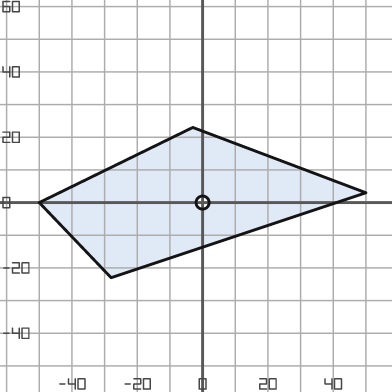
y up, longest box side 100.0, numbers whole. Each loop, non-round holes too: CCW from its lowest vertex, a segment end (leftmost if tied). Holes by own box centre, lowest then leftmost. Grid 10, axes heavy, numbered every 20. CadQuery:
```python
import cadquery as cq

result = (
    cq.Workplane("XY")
    .moveTo(-28.0, -23.0)
    .lineTo(50.0, 3.0)
    .lineTo(-3.0, 23.0)
    .lineTo(-50.0, 0.0)
    .close()
    .moveTo(0.0, 0.0)
    .circle(2.0)
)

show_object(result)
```